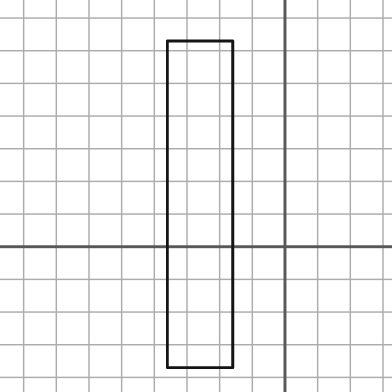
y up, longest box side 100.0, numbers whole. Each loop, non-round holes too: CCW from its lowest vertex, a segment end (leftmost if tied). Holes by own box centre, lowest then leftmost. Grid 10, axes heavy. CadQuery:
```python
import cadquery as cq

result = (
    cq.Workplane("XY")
    .moveTo(-36.0, -37.0)
    .lineTo(-16.0, -37.0)
    .lineTo(-16.0, 63.0)
    .lineTo(-36.0, 63.0)
    .close()
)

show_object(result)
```